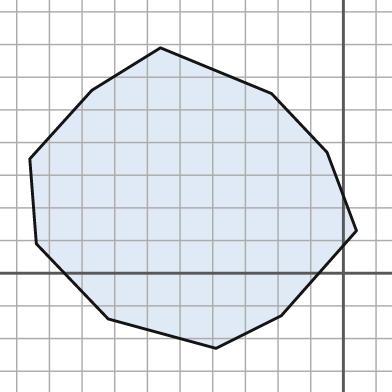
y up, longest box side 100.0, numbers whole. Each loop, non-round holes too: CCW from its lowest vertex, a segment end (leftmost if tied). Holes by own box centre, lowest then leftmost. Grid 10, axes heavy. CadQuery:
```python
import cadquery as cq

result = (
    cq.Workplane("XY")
    .moveTo(-39.0, -23.0)
    .lineTo(-19.0, -13.0)
    .lineTo(4.0, 13.0)
    .lineTo(-5.0, 37.0)
    .lineTo(-22.0, 55.0)
    .lineTo(-56.0, 69.0)
    .lineTo(-77.0, 56.0)
    .lineTo(-96.0, 35.0)
    .lineTo(-94.0, 9.0)
    .lineTo(-72.0, -14.0)
    .close()
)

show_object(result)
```